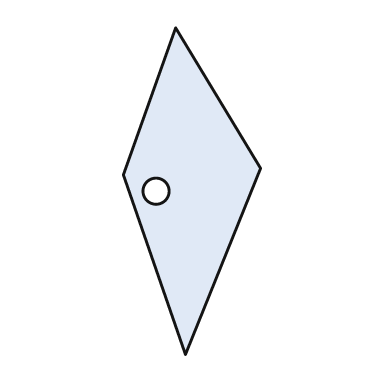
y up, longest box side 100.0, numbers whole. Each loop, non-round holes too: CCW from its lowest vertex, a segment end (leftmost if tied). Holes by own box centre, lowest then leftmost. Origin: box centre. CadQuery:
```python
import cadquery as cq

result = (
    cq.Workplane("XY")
    .moveTo(-2.0, -50.0)
    .lineTo(21.0, 7.0)
    .lineTo(-5.0, 50.0)
    .lineTo(-21.0, 5.0)
    .close()
    .moveTo(-11.0, 0.0)
    .circle(4.0)
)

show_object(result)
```